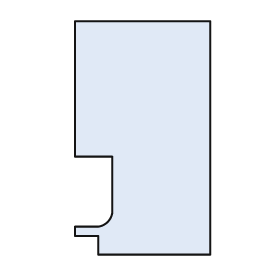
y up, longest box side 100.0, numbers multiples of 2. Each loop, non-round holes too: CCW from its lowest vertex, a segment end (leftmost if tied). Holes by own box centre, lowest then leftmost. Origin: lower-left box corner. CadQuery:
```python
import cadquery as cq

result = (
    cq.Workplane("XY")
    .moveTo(10.0, 0.0)
    .lineTo(58.0, 0.0)
    .lineTo(58.0, 100.0)
    .lineTo(0.0, 100.0)
    .lineTo(0.0, 42.0)
    .lineTo(16.0, 42.0)
    .lineTo(16.0, 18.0)
    .threePointArc((14.0, 14.0), (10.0, 12.0))
    .lineTo(0.0, 12.0)
    .lineTo(0.0, 8.0)
    .lineTo(10.0, 8.0)
    .close()
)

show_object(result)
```